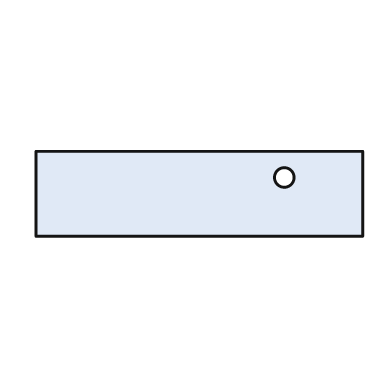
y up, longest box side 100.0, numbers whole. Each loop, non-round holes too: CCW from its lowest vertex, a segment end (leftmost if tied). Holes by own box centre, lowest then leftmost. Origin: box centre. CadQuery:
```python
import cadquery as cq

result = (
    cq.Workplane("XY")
    .moveTo(-50.0, -13.0)
    .lineTo(50.0, -13.0)
    .lineTo(50.0, 13.0)
    .lineTo(-50.0, 13.0)
    .close()
    .moveTo(26.0, 5.0)
    .circle(3.0)
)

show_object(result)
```